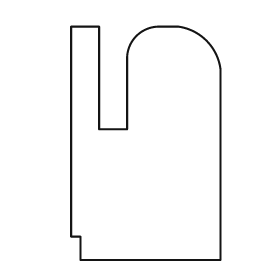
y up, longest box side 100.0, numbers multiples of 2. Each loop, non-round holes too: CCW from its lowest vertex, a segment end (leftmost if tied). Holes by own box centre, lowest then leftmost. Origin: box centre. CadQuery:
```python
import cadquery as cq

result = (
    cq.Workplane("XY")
    .moveTo(-28.0, -50.0)
    .lineTo(32.0, -50.0)
    .lineTo(32.0, 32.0)
    .threePointArc((26.0, 44.0), (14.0, 50.0))
    .lineTo(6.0, 50.0)
    .threePointArc((-4.0, 46.0), (-8.0, 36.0))
    .lineTo(-8.0, 6.0)
    .lineTo(-20.0, 6.0)
    .lineTo(-20.0, 50.0)
    .lineTo(-32.0, 50.0)
    .lineTo(-32.0, -40.0)
    .lineTo(-28.0, -40.0)
    .close()
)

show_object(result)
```